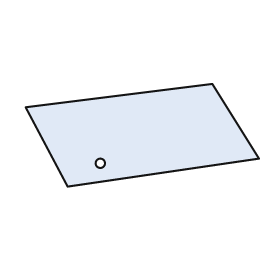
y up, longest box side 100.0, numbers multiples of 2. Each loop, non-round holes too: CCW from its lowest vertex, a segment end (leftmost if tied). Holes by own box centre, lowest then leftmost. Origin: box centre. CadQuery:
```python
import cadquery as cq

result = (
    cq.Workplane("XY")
    .moveTo(-32.0, -22.0)
    .lineTo(50.0, -10.0)
    .lineTo(30.0, 22.0)
    .lineTo(-50.0, 12.0)
    .close()
    .moveTo(-18.0, -12.0)
    .circle(2.0)
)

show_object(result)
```